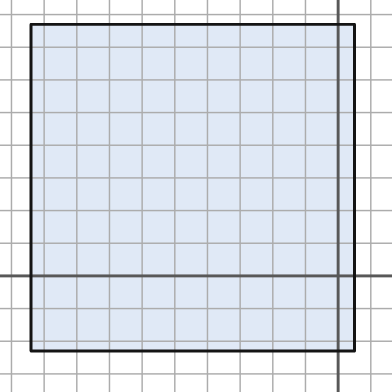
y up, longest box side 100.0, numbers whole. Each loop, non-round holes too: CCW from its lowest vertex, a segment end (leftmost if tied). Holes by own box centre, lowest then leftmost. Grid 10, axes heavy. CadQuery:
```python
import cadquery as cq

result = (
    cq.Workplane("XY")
    .moveTo(-94.0, -23.0)
    .lineTo(5.0, -23.0)
    .lineTo(5.0, 77.0)
    .lineTo(-94.0, 77.0)
    .close()
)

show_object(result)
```